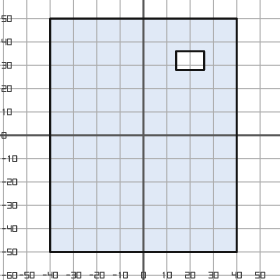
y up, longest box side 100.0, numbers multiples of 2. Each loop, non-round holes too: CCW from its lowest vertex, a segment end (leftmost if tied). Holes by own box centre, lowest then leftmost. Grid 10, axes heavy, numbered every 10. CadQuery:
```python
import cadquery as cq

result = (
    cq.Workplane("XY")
    .moveTo(-40.0, -50.0)
    .lineTo(40.0, -50.0)
    .lineTo(40.0, 50.0)
    .lineTo(-40.0, 50.0)
    .close()
    .moveTo(14.0, 28.0)
    .lineTo(26.0, 28.0)
    .lineTo(26.0, 36.0)
    .lineTo(14.0, 36.0)
    .close()
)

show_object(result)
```